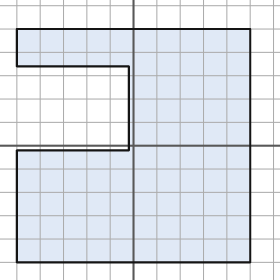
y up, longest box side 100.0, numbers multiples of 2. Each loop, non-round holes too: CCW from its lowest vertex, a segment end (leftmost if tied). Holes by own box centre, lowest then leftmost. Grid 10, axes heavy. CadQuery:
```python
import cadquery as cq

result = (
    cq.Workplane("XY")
    .moveTo(-50.0, -50.0)
    .lineTo(50.0, -50.0)
    .lineTo(50.0, 50.0)
    .lineTo(-50.0, 50.0)
    .lineTo(-50.0, 34.0)
    .lineTo(-2.0, 34.0)
    .lineTo(-2.0, -2.0)
    .lineTo(-50.0, -2.0)
    .close()
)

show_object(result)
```